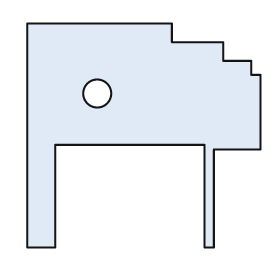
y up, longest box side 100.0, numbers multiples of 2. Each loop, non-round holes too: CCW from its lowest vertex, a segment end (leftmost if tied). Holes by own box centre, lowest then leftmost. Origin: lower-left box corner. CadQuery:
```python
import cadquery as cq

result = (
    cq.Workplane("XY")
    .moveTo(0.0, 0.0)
    .lineTo(12.0, 0.0)
    .lineTo(12.0, 44.0)
    .lineTo(76.0, 44.0)
    .lineTo(76.0, 0.0)
    .lineTo(80.0, 0.0)
    .lineTo(80.0, 42.0)
    .lineTo(100.0, 42.0)
    .lineTo(100.0, 74.0)
    .lineTo(96.0, 74.0)
    .lineTo(96.0, 80.0)
    .lineTo(84.0, 80.0)
    .lineTo(84.0, 88.0)
    .lineTo(62.0, 88.0)
    .lineTo(62.0, 96.0)
    .lineTo(0.0, 96.0)
    .close()
    .moveTo(30.0, 66.0)
    .circle(6.0)
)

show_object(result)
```